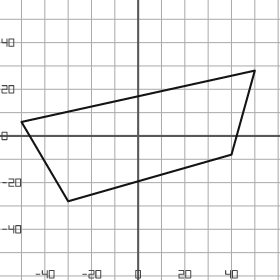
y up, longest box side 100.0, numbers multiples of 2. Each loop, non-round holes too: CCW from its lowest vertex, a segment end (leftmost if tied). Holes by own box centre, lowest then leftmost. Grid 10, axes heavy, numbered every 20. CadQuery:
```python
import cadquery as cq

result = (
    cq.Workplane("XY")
    .moveTo(-30.0, -28.0)
    .lineTo(40.0, -8.0)
    .lineTo(50.0, 28.0)
    .lineTo(-50.0, 6.0)
    .close()
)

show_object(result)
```